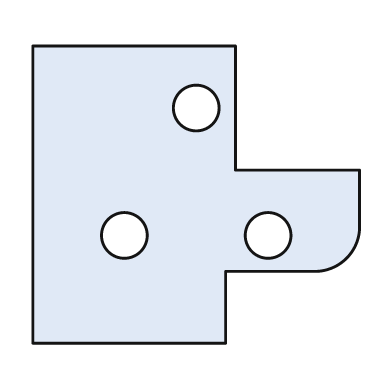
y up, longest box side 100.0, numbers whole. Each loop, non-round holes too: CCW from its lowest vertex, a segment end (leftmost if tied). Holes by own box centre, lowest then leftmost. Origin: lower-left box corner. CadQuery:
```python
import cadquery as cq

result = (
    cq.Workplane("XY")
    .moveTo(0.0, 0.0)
    .lineTo(59.0, 0.0)
    .lineTo(59.0, 22.0)
    .lineTo(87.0, 22.0)
    .threePointArc((96.0, 26.0), (100.0, 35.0))
    .lineTo(100.0, 53.0)
    .lineTo(62.0, 53.0)
    .lineTo(62.0, 91.0)
    .lineTo(0.0, 91.0)
    .close()
    .moveTo(28.0, 33.0)
    .circle(7.0)
    .moveTo(72.0, 33.0)
    .circle(7.0)
    .moveTo(50.0, 72.0)
    .circle(7.0)
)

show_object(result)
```